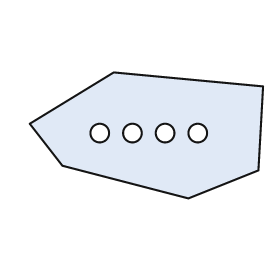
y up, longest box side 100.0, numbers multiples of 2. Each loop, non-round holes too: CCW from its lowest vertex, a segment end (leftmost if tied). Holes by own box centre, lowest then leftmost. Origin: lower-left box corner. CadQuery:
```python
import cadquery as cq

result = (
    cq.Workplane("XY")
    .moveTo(68.0, 0.0)
    .lineTo(98.0, 12.0)
    .lineTo(100.0, 48.0)
    .lineTo(36.0, 54.0)
    .lineTo(0.0, 32.0)
    .lineTo(14.0, 14.0)
    .close()
    .moveTo(30.0, 28.0)
    .circle(4.0)
    .moveTo(44.0, 28.0)
    .circle(4.0)
    .moveTo(58.0, 28.0)
    .circle(4.0)
    .moveTo(72.0, 28.0)
    .circle(4.0)
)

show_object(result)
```